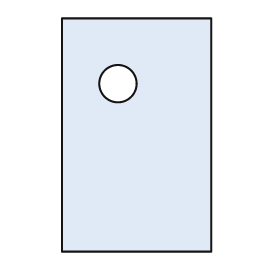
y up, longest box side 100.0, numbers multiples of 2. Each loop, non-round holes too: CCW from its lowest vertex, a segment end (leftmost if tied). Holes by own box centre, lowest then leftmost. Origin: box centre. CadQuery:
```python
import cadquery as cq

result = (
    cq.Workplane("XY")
    .moveTo(-32.0, -50.0)
    .lineTo(32.0, -50.0)
    .lineTo(32.0, 50.0)
    .lineTo(-32.0, 50.0)
    .close()
    .moveTo(-8.0, 22.0)
    .circle(8.0)
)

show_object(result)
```